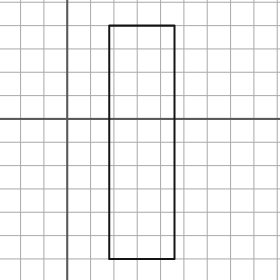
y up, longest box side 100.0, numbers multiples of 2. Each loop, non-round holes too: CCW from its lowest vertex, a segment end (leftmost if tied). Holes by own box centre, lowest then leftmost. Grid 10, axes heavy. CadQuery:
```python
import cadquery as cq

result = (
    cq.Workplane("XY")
    .moveTo(18.0, -60.0)
    .lineTo(46.0, -60.0)
    .lineTo(46.0, 40.0)
    .lineTo(18.0, 40.0)
    .close()
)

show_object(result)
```